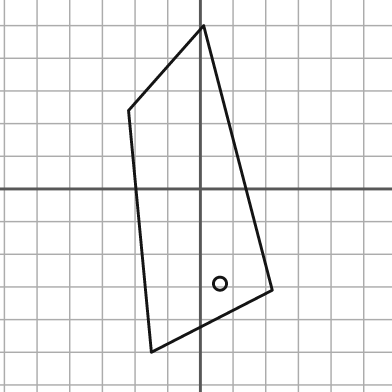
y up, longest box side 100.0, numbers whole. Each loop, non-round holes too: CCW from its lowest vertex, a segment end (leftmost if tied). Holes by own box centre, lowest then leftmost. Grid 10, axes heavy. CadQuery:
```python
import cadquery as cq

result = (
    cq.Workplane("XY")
    .moveTo(-15.0, -50.0)
    .lineTo(22.0, -31.0)
    .lineTo(1.0, 50.0)
    .lineTo(-22.0, 24.0)
    .close()
    .moveTo(6.0, -29.0)
    .circle(2.0)
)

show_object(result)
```